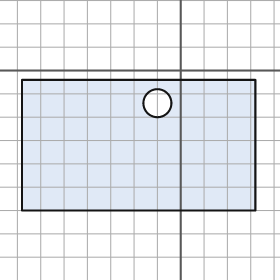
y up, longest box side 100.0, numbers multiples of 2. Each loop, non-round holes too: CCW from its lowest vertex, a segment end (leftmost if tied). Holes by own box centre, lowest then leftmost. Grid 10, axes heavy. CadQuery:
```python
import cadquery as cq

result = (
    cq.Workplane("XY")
    .moveTo(-68.0, -60.0)
    .lineTo(32.0, -60.0)
    .lineTo(32.0, -4.0)
    .lineTo(-68.0, -4.0)
    .close()
    .moveTo(-10.0, -14.0)
    .circle(6.0)
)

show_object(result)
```